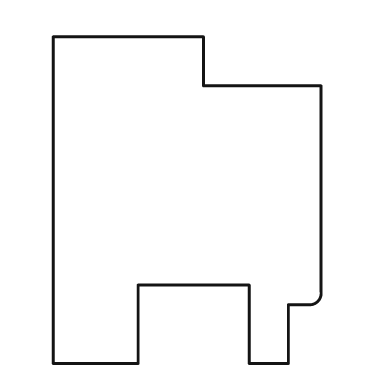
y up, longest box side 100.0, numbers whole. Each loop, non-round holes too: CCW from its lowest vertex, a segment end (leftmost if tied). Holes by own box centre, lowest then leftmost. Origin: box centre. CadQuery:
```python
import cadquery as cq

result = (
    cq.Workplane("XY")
    .moveTo(-41.0, -50.0)
    .lineTo(-15.0, -50.0)
    .lineTo(-15.0, -26.0)
    .lineTo(19.0, -26.0)
    .lineTo(19.0, -50.0)
    .lineTo(31.0, -50.0)
    .lineTo(31.0, -32.0)
    .lineTo(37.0, -32.0)
    .threePointArc((40.0, -31.0), (41.0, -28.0))
    .lineTo(41.0, 35.0)
    .lineTo(5.0, 35.0)
    .lineTo(5.0, 50.0)
    .lineTo(-41.0, 50.0)
    .close()
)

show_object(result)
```